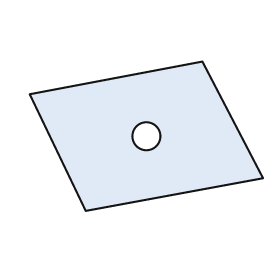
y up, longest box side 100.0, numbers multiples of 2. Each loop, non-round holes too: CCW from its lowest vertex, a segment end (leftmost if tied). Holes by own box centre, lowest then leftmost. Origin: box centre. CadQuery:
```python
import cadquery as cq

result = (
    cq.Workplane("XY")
    .moveTo(-26.0, -32.0)
    .lineTo(50.0, -18.0)
    .lineTo(24.0, 32.0)
    .lineTo(-50.0, 18.0)
    .close()
    .moveTo(0.0, 0.0)
    .circle(6.0)
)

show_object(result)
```